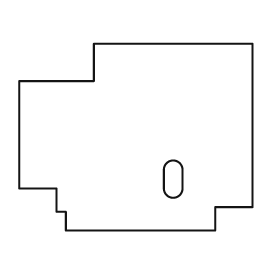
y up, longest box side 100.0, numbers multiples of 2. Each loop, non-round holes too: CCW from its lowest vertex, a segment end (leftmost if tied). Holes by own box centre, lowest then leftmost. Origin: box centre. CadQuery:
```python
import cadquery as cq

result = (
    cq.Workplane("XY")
    .moveTo(-30.0, -40.0)
    .lineTo(34.0, -40.0)
    .lineTo(34.0, -30.0)
    .lineTo(50.0, -30.0)
    .lineTo(50.0, 40.0)
    .lineTo(-18.0, 40.0)
    .lineTo(-18.0, 24.0)
    .lineTo(-50.0, 24.0)
    .lineTo(-50.0, -22.0)
    .lineTo(-34.0, -22.0)
    .lineTo(-34.0, -32.0)
    .lineTo(-30.0, -32.0)
    .close()
    .moveTo(12.0, -22.0)
    .threePointArc((16.0, -26.0), (20.0, -22.0))
    .lineTo(20.0, -14.0)
    .threePointArc((16.0, -10.0), (12.0, -14.0))
    .close()
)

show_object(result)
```